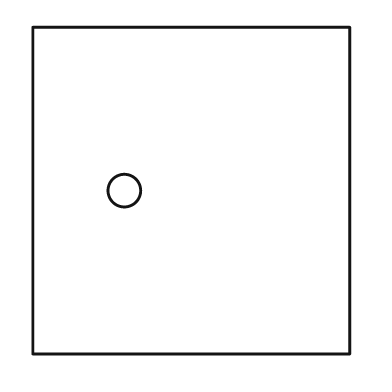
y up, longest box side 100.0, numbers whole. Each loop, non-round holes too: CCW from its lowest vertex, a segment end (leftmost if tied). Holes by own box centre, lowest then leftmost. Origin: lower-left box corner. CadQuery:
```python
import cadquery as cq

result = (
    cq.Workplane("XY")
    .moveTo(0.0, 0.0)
    .lineTo(97.0, 0.0)
    .lineTo(97.0, 100.0)
    .lineTo(0.0, 100.0)
    .close()
    .moveTo(28.0, 50.0)
    .circle(5.0)
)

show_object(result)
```